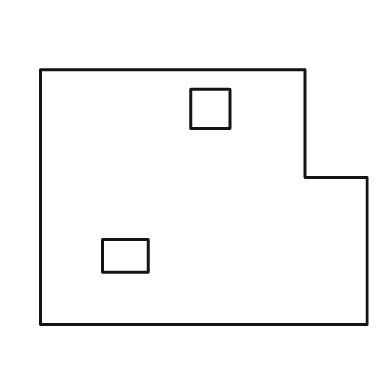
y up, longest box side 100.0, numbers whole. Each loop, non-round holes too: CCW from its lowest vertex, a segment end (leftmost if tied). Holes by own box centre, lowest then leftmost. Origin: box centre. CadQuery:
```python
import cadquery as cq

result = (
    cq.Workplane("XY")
    .moveTo(-50.0, -39.0)
    .lineTo(50.0, -39.0)
    .lineTo(50.0, 6.0)
    .lineTo(31.0, 6.0)
    .lineTo(31.0, 39.0)
    .lineTo(-50.0, 39.0)
    .close()
    .moveTo(-31.0, -23.0)
    .lineTo(-17.0, -23.0)
    .lineTo(-17.0, -13.0)
    .lineTo(-31.0, -13.0)
    .close()
    .moveTo(-4.0, 21.0)
    .lineTo(8.0, 21.0)
    .lineTo(8.0, 33.0)
    .lineTo(-4.0, 33.0)
    .close()
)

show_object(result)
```